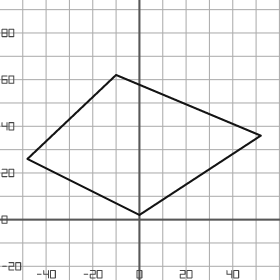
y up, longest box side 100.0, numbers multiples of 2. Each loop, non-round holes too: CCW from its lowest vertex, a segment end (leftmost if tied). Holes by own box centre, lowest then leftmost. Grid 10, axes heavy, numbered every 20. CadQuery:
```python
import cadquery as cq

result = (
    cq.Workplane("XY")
    .moveTo(0.0, 2.0)
    .lineTo(52.0, 36.0)
    .lineTo(-10.0, 62.0)
    .lineTo(-48.0, 26.0)
    .close()
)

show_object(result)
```